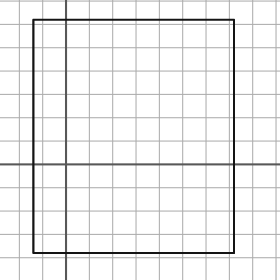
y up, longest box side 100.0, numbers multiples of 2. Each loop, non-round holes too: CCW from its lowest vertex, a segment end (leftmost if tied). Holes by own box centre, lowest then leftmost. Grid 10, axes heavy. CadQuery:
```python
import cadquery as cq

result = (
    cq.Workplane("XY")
    .moveTo(-14.0, -38.0)
    .lineTo(72.0, -38.0)
    .lineTo(72.0, 62.0)
    .lineTo(-14.0, 62.0)
    .close()
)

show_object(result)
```